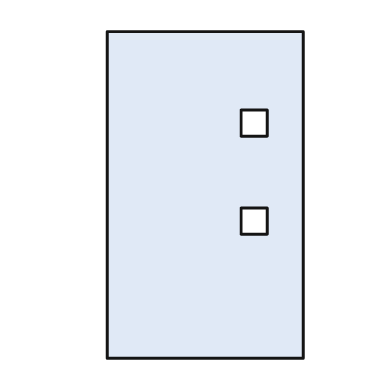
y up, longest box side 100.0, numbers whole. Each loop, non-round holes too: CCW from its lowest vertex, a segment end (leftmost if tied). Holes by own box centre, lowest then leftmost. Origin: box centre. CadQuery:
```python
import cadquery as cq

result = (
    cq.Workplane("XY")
    .moveTo(-30.0, -50.0)
    .lineTo(30.0, -50.0)
    .lineTo(30.0, 50.0)
    .lineTo(-30.0, 50.0)
    .close()
    .moveTo(11.0, -12.0)
    .lineTo(19.0, -12.0)
    .lineTo(19.0, -4.0)
    .lineTo(11.0, -4.0)
    .close()
    .moveTo(11.0, 18.0)
    .lineTo(19.0, 18.0)
    .lineTo(19.0, 26.0)
    .lineTo(11.0, 26.0)
    .close()
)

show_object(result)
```